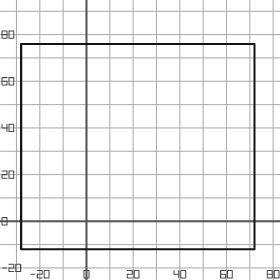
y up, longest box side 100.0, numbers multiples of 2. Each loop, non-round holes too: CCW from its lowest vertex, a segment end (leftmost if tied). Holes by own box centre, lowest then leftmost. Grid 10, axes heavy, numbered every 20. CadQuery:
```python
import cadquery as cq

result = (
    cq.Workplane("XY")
    .moveTo(-28.0, -12.0)
    .lineTo(72.0, -12.0)
    .lineTo(72.0, 76.0)
    .lineTo(-28.0, 76.0)
    .close()
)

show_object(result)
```